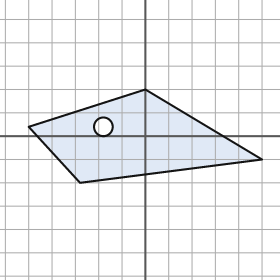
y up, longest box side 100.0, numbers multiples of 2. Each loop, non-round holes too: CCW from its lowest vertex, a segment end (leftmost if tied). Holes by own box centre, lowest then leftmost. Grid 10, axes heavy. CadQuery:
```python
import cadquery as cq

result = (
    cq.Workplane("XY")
    .moveTo(-28.0, -20.0)
    .lineTo(50.0, -10.0)
    .lineTo(0.0, 20.0)
    .lineTo(-50.0, 4.0)
    .close()
    .moveTo(-18.0, 4.0)
    .circle(4.0)
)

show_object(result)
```